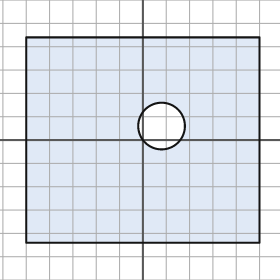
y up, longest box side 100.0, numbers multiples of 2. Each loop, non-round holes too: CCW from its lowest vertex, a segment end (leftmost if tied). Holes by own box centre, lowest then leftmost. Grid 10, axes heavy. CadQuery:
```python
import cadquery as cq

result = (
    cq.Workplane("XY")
    .moveTo(-50.0, -44.0)
    .lineTo(50.0, -44.0)
    .lineTo(50.0, 44.0)
    .lineTo(-50.0, 44.0)
    .close()
    .moveTo(8.0, 6.0)
    .circle(10.0)
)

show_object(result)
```